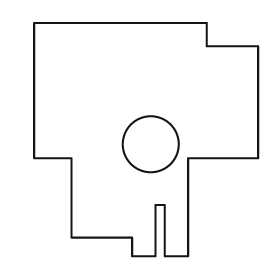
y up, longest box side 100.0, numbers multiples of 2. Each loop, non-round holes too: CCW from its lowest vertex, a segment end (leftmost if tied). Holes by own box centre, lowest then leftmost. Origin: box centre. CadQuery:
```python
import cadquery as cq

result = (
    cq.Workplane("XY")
    .moveTo(-6.0, -50.0)
    .lineTo(4.0, -50.0)
    .lineTo(4.0, -28.0)
    .lineTo(8.0, -28.0)
    .lineTo(8.0, -50.0)
    .lineTo(18.0, -50.0)
    .lineTo(18.0, -8.0)
    .lineTo(48.0, -8.0)
    .lineTo(48.0, 40.0)
    .lineTo(26.0, 40.0)
    .lineTo(26.0, 50.0)
    .lineTo(-48.0, 50.0)
    .lineTo(-48.0, -8.0)
    .lineTo(-32.0, -8.0)
    .lineTo(-32.0, -42.0)
    .lineTo(-6.0, -42.0)
    .close()
    .moveTo(2.0, -2.0)
    .circle(12.0)
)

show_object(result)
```